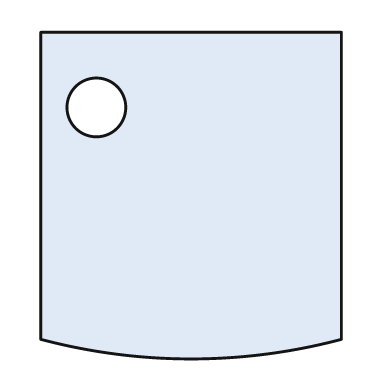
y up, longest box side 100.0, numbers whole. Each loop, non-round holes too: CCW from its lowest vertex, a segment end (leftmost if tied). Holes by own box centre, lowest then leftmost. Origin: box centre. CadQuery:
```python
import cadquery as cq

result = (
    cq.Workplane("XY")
    .moveTo(-46.0, -44.0)
    .threePointArc((0.0, -50.0), (46.0, -44.0))
    .lineTo(46.0, 50.0)
    .lineTo(-46.0, 50.0)
    .close()
    .moveTo(-29.0, 27.0)
    .circle(9.0)
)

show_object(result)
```